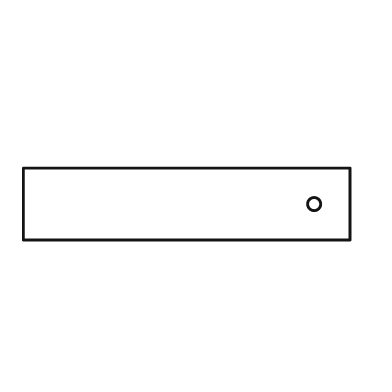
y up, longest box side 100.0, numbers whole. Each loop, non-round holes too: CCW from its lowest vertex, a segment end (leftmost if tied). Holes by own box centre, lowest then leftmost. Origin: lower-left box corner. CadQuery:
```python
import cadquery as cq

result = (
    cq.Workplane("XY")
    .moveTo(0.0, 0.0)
    .lineTo(100.0, 0.0)
    .lineTo(100.0, 22.0)
    .lineTo(0.0, 22.0)
    .close()
    .moveTo(89.0, 11.0)
    .circle(2.0)
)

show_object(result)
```